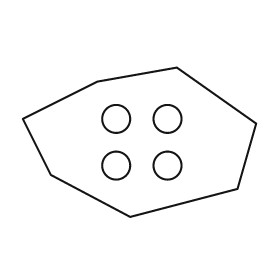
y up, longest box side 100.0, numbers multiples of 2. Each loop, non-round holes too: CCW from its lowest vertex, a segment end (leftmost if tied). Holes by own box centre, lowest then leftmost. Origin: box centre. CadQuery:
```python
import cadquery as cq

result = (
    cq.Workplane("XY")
    .moveTo(-4.0, -32.0)
    .lineTo(42.0, -20.0)
    .lineTo(50.0, 8.0)
    .lineTo(16.0, 32.0)
    .lineTo(-18.0, 26.0)
    .lineTo(-50.0, 10.0)
    .lineTo(-38.0, -14.0)
    .close()
    .moveTo(-10.0, -10.0)
    .circle(6.0)
    .moveTo(12.0, -10.0)
    .circle(6.0)
    .moveTo(-10.0, 10.0)
    .circle(6.0)
    .moveTo(12.0, 10.0)
    .circle(6.0)
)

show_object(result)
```